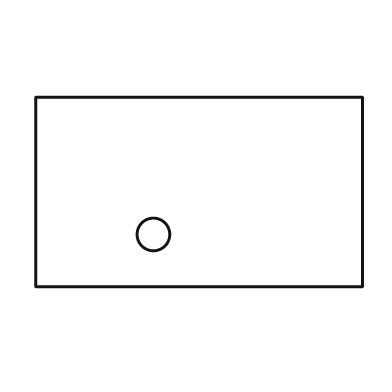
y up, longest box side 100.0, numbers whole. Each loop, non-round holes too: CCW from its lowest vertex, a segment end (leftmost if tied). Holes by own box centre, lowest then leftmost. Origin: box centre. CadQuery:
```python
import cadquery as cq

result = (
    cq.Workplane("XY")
    .moveTo(-50.0, -29.0)
    .lineTo(50.0, -29.0)
    .lineTo(50.0, 29.0)
    .lineTo(-50.0, 29.0)
    .close()
    .moveTo(-14.0, -13.0)
    .circle(5.0)
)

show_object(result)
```